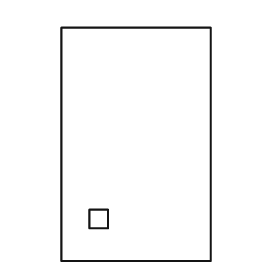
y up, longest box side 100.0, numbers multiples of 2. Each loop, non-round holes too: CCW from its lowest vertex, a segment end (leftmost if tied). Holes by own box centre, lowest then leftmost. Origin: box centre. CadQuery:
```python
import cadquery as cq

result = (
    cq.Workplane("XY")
    .moveTo(-32.0, -50.0)
    .lineTo(32.0, -50.0)
    .lineTo(32.0, 50.0)
    .lineTo(-32.0, 50.0)
    .close()
    .moveTo(-20.0, -36.0)
    .lineTo(-12.0, -36.0)
    .lineTo(-12.0, -28.0)
    .lineTo(-20.0, -28.0)
    .close()
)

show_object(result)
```